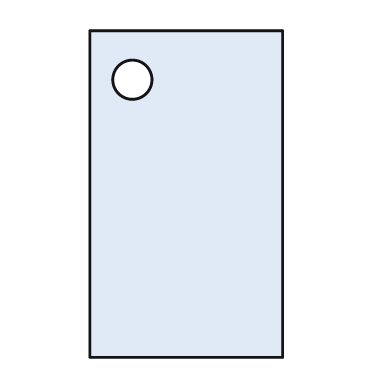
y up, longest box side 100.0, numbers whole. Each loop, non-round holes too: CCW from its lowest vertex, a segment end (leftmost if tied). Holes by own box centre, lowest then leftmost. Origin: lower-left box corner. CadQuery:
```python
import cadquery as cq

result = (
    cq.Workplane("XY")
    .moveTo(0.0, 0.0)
    .lineTo(59.0, 0.0)
    .lineTo(59.0, 100.0)
    .lineTo(0.0, 100.0)
    .close()
    .moveTo(13.0, 85.0)
    .circle(6.0)
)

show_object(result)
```